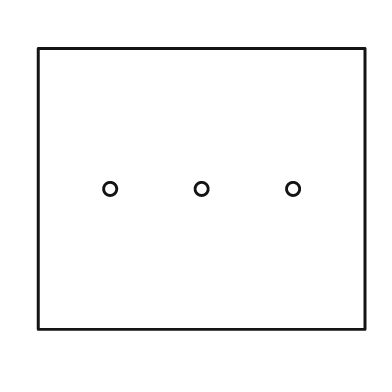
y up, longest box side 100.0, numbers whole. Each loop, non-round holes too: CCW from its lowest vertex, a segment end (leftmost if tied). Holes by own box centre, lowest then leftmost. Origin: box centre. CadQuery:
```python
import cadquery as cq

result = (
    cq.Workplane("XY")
    .moveTo(-50.0, -43.0)
    .lineTo(50.0, -43.0)
    .lineTo(50.0, 43.0)
    .lineTo(-50.0, 43.0)
    .close()
    .moveTo(-28.0, 0.0)
    .circle(2.0)
    .moveTo(0.0, 0.0)
    .circle(2.0)
    .moveTo(28.0, 0.0)
    .circle(2.0)
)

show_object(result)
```